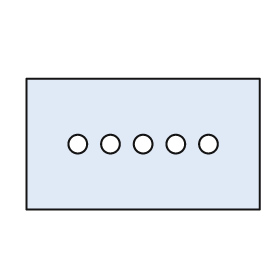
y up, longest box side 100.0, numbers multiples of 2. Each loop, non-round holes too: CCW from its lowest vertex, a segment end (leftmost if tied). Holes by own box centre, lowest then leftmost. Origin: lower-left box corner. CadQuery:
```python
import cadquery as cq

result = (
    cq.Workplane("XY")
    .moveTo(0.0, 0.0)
    .lineTo(100.0, 0.0)
    .lineTo(100.0, 56.0)
    .lineTo(0.0, 56.0)
    .close()
    .moveTo(22.0, 28.0)
    .circle(4.0)
    .moveTo(36.0, 28.0)
    .circle(4.0)
    .moveTo(50.0, 28.0)
    .circle(4.0)
    .moveTo(64.0, 28.0)
    .circle(4.0)
    .moveTo(78.0, 28.0)
    .circle(4.0)
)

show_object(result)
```